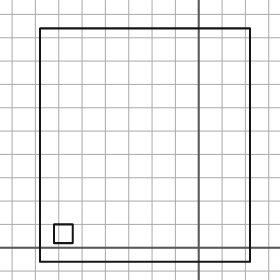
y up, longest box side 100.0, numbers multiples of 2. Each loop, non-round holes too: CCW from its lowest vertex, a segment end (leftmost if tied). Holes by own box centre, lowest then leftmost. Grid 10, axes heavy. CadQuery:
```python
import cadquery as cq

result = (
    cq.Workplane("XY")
    .moveTo(-68.0, -6.0)
    .lineTo(22.0, -6.0)
    .lineTo(22.0, 94.0)
    .lineTo(-68.0, 94.0)
    .close()
    .moveTo(-62.0, 2.0)
    .lineTo(-54.0, 2.0)
    .lineTo(-54.0, 10.0)
    .lineTo(-62.0, 10.0)
    .close()
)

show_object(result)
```